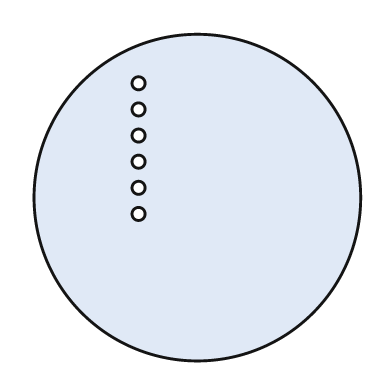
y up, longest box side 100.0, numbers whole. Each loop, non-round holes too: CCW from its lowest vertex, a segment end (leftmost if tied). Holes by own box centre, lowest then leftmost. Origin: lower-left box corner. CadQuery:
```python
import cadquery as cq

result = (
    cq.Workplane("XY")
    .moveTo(50.0, 50.0)
    .circle(50.0)
    .moveTo(32.0, 45.0)
    .circle(2.0)
    .moveTo(32.0, 53.0)
    .circle(2.0)
    .moveTo(32.0, 61.0)
    .circle(2.0)
    .moveTo(32.0, 69.0)
    .circle(2.0)
    .moveTo(32.0, 77.0)
    .circle(2.0)
    .moveTo(32.0, 85.0)
    .circle(2.0)
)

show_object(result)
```